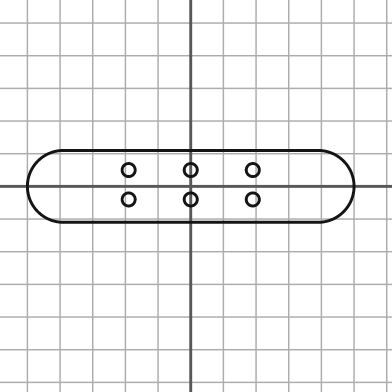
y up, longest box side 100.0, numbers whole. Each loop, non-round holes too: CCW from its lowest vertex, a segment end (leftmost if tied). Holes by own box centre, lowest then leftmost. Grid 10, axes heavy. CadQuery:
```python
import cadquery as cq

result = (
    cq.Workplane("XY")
    .moveTo(-39.0, -11.0)
    .lineTo(39.0, -11.0)
    .threePointArc((50.0, 0.0), (39.0, 11.0))
    .lineTo(-39.0, 11.0)
    .threePointArc((-50.0, 0.0), (-39.0, -11.0))
    .close()
    .moveTo(-19.0, -4.0)
    .circle(2.0)
    .moveTo(0.0, -4.0)
    .circle(2.0)
    .moveTo(19.0, -4.0)
    .circle(2.0)
    .moveTo(-19.0, 5.0)
    .circle(2.0)
    .moveTo(0.0, 5.0)
    .circle(2.0)
    .moveTo(19.0, 5.0)
    .circle(2.0)
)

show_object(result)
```